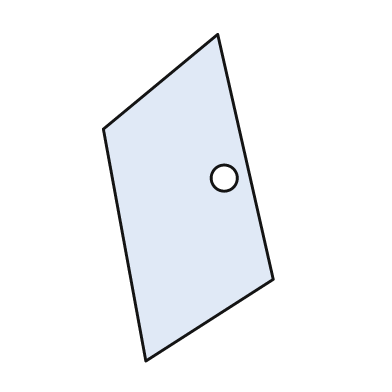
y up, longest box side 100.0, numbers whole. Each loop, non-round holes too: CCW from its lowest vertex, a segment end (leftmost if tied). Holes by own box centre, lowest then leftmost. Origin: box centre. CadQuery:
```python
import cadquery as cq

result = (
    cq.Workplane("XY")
    .moveTo(-13.0, -50.0)
    .lineTo(26.0, -25.0)
    .lineTo(9.0, 50.0)
    .lineTo(-26.0, 21.0)
    .close()
    .moveTo(11.0, 6.0)
    .circle(4.0)
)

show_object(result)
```